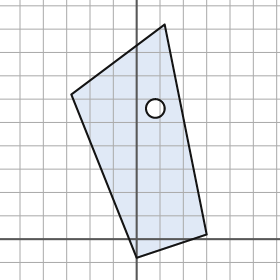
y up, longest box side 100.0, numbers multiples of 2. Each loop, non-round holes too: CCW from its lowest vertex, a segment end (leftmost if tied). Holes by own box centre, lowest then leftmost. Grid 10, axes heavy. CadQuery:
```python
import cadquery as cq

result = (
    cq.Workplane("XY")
    .moveTo(0.0, -8.0)
    .lineTo(30.0, 2.0)
    .lineTo(12.0, 92.0)
    .lineTo(-28.0, 62.0)
    .close()
    .moveTo(8.0, 56.0)
    .circle(4.0)
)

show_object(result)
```